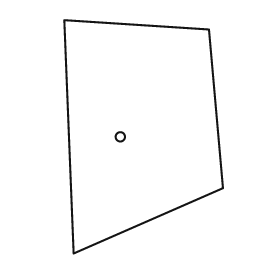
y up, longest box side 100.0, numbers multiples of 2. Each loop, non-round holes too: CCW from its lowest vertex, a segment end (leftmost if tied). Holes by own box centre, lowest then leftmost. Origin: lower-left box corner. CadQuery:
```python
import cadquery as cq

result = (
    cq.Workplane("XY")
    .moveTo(4.0, 0.0)
    .lineTo(68.0, 28.0)
    .lineTo(62.0, 96.0)
    .lineTo(0.0, 100.0)
    .close()
    .moveTo(24.0, 50.0)
    .circle(2.0)
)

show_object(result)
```